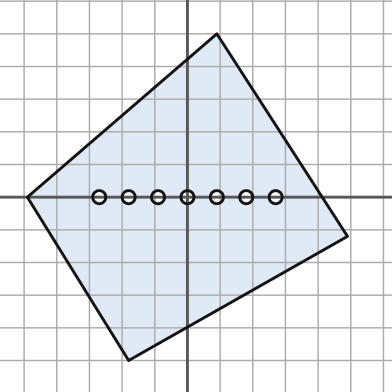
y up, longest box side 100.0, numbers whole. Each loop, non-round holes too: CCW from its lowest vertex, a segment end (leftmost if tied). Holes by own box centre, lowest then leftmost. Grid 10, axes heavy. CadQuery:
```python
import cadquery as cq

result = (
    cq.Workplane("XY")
    .moveTo(-18.0, -50.0)
    .lineTo(49.0, -12.0)
    .lineTo(9.0, 50.0)
    .lineTo(-49.0, 0.0)
    .close()
    .moveTo(-27.0, 0.0)
    .circle(2.0)
    .moveTo(-18.0, 0.0)
    .circle(2.0)
    .moveTo(-9.0, 0.0)
    .circle(2.0)
    .moveTo(0.0, 0.0)
    .circle(2.0)
    .moveTo(9.0, 0.0)
    .circle(2.0)
    .moveTo(18.0, 0.0)
    .circle(2.0)
    .moveTo(27.0, 0.0)
    .circle(2.0)
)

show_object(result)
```